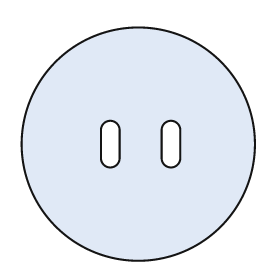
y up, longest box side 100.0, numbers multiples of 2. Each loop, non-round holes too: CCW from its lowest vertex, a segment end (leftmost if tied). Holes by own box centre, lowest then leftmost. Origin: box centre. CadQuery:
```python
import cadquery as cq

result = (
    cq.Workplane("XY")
    .moveTo(0.0, 0.0)
    .circle(50.0)
    .moveTo(-16.0, -6.0)
    .threePointArc((-12.0, -10.0), (-8.0, -6.0))
    .lineTo(-8.0, 6.0)
    .threePointArc((-12.0, 10.0), (-16.0, 6.0))
    .close()
    .moveTo(10.0, -6.0)
    .threePointArc((14.0, -10.0), (18.0, -6.0))
    .lineTo(18.0, 6.0)
    .threePointArc((14.0, 10.0), (10.0, 6.0))
    .close()
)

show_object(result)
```